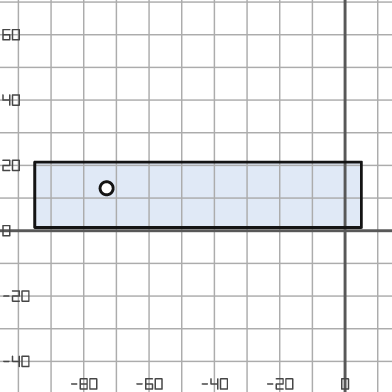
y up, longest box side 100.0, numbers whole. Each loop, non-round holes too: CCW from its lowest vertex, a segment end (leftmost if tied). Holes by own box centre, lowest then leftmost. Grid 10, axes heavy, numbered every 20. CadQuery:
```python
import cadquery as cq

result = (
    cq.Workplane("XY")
    .moveTo(-95.0, 1.0)
    .lineTo(5.0, 1.0)
    .lineTo(5.0, 21.0)
    .lineTo(-95.0, 21.0)
    .close()
    .moveTo(-73.0, 13.0)
    .circle(2.0)
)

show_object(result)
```